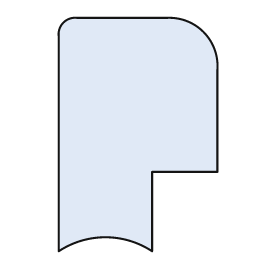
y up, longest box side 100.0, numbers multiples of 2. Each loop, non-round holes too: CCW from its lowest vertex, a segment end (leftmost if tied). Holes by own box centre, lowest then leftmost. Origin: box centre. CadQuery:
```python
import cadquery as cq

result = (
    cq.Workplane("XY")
    .moveTo(-34.0, -50.0)
    .threePointArc((-14.0, -44.0), (6.0, -50.0))
    .lineTo(6.0, -16.0)
    .lineTo(34.0, -16.0)
    .lineTo(34.0, 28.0)
    .threePointArc((28.0, 44.0), (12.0, 50.0))
    .lineTo(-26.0, 50.0)
    .threePointArc((-32.0, 48.0), (-34.0, 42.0))
    .close()
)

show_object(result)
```